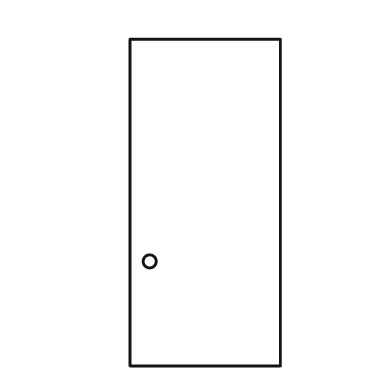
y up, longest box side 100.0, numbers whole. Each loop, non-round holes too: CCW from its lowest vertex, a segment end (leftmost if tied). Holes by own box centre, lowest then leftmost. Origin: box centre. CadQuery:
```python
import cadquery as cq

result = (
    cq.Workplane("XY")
    .moveTo(-23.0, -50.0)
    .lineTo(23.0, -50.0)
    .lineTo(23.0, 50.0)
    .lineTo(-23.0, 50.0)
    .close()
    .moveTo(-17.0, -18.0)
    .circle(2.0)
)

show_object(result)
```